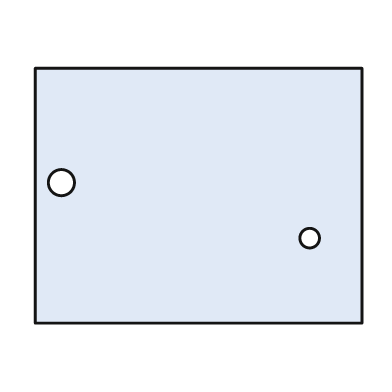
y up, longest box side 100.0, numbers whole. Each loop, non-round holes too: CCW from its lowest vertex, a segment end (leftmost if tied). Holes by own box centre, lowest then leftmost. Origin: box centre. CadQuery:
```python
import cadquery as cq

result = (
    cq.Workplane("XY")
    .moveTo(-50.0, -39.0)
    .lineTo(50.0, -39.0)
    .lineTo(50.0, 39.0)
    .lineTo(-50.0, 39.0)
    .close()
    .moveTo(34.0, -13.0)
    .circle(3.0)
    .moveTo(-42.0, 4.0)
    .circle(4.0)
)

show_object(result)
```